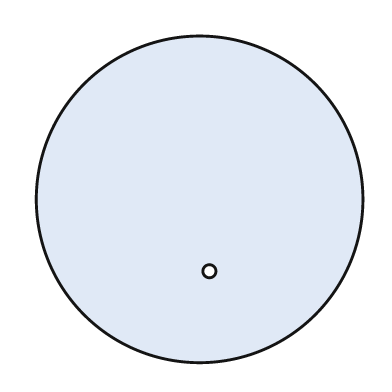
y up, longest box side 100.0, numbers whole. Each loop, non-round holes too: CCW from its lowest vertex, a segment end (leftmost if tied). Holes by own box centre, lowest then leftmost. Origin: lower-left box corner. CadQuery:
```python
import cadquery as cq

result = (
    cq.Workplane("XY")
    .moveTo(50.0, 50.0)
    .circle(50.0)
    .moveTo(53.0, 28.0)
    .circle(2.0)
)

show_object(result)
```